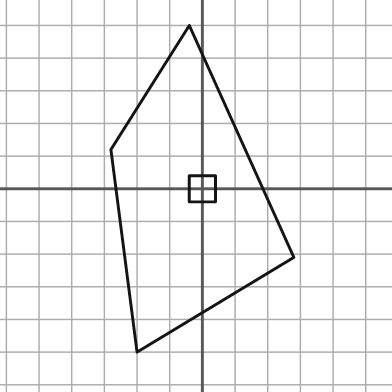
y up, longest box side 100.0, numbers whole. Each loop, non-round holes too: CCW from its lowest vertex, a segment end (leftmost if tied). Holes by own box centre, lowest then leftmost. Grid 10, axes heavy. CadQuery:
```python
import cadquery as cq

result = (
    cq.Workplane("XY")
    .moveTo(-20.0, -50.0)
    .lineTo(28.0, -21.0)
    .lineTo(-4.0, 50.0)
    .lineTo(-28.0, 12.0)
    .close()
    .moveTo(-4.0, -4.0)
    .lineTo(4.0, -4.0)
    .lineTo(4.0, 4.0)
    .lineTo(-4.0, 4.0)
    .close()
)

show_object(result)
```